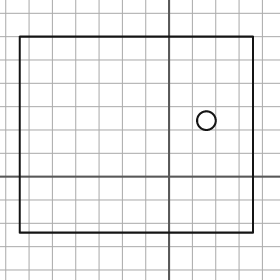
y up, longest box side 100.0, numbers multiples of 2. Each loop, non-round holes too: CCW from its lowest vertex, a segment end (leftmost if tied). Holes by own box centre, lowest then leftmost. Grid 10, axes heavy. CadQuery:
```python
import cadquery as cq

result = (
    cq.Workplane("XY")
    .moveTo(-64.0, -24.0)
    .lineTo(36.0, -24.0)
    .lineTo(36.0, 60.0)
    .lineTo(-64.0, 60.0)
    .close()
    .moveTo(16.0, 24.0)
    .circle(4.0)
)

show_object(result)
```